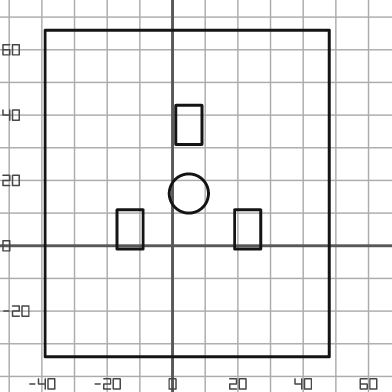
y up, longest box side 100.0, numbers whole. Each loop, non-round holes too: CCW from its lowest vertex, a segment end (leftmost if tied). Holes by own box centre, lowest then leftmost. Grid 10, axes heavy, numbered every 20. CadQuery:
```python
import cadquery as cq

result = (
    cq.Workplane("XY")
    .moveTo(-39.0, -34.0)
    .lineTo(48.0, -34.0)
    .lineTo(48.0, 66.0)
    .lineTo(-39.0, 66.0)
    .close()
    .moveTo(-17.0, -1.0)
    .lineTo(-9.0, -1.0)
    .lineTo(-9.0, 11.0)
    .lineTo(-17.0, 11.0)
    .close()
    .moveTo(19.0, -1.0)
    .lineTo(27.0, -1.0)
    .lineTo(27.0, 11.0)
    .lineTo(19.0, 11.0)
    .close()
    .moveTo(5.0, 16.0)
    .circle(6.0)
    .moveTo(1.0, 31.0)
    .lineTo(9.0, 31.0)
    .lineTo(9.0, 43.0)
    .lineTo(1.0, 43.0)
    .close()
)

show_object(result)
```